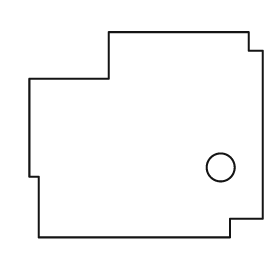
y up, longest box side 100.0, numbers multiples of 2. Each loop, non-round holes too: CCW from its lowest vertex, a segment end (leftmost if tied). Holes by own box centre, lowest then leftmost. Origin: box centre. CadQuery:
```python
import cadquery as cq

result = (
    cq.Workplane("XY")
    .moveTo(-46.0, -44.0)
    .lineTo(36.0, -44.0)
    .lineTo(36.0, -36.0)
    .lineTo(50.0, -36.0)
    .lineTo(50.0, 36.0)
    .lineTo(44.0, 36.0)
    .lineTo(44.0, 44.0)
    .lineTo(-16.0, 44.0)
    .lineTo(-16.0, 24.0)
    .lineTo(-50.0, 24.0)
    .lineTo(-50.0, -18.0)
    .lineTo(-46.0, -18.0)
    .close()
    .moveTo(32.0, -14.0)
    .circle(6.0)
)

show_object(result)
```